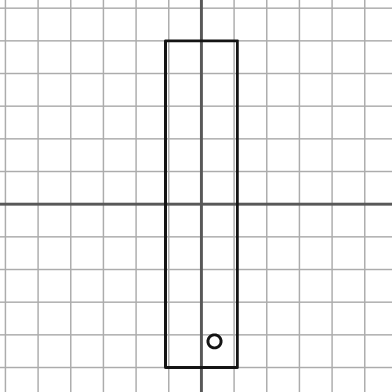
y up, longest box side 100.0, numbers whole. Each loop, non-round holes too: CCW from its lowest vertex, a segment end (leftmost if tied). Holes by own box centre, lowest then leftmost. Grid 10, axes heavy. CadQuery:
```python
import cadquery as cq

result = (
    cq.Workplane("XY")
    .moveTo(-11.0, -50.0)
    .lineTo(11.0, -50.0)
    .lineTo(11.0, 50.0)
    .lineTo(-11.0, 50.0)
    .close()
    .moveTo(4.0, -42.0)
    .circle(2.0)
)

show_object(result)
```